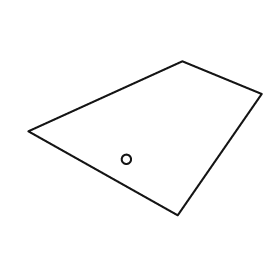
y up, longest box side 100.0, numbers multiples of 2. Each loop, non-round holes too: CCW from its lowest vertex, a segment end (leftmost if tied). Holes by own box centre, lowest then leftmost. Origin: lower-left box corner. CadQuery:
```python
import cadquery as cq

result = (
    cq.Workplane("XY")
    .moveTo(64.0, 0.0)
    .lineTo(100.0, 52.0)
    .lineTo(66.0, 66.0)
    .lineTo(0.0, 36.0)
    .close()
    .moveTo(42.0, 24.0)
    .circle(2.0)
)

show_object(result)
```